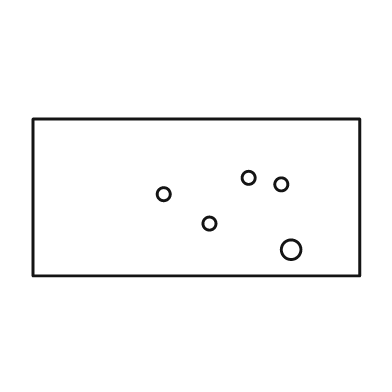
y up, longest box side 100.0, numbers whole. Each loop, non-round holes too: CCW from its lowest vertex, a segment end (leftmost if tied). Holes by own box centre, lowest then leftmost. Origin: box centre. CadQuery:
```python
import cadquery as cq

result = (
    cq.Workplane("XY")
    .moveTo(-50.0, -24.0)
    .lineTo(50.0, -24.0)
    .lineTo(50.0, 24.0)
    .lineTo(-50.0, 24.0)
    .close()
    .moveTo(29.0, -16.0)
    .circle(3.0)
    .moveTo(4.0, -8.0)
    .circle(2.0)
    .moveTo(-10.0, 1.0)
    .circle(2.0)
    .moveTo(26.0, 4.0)
    .circle(2.0)
    .moveTo(16.0, 6.0)
    .circle(2.0)
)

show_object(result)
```